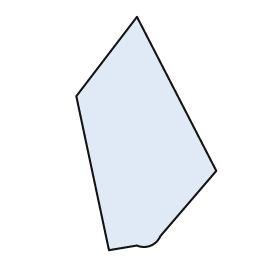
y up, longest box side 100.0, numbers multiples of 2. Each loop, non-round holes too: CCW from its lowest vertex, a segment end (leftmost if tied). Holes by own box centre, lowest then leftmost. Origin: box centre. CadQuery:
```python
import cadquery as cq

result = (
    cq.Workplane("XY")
    .moveTo(-16.0, -50.0)
    .lineTo(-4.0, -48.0)
    .threePointArc((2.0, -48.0), (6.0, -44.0))
    .lineTo(30.0, -16.0)
    .lineTo(-4.0, 50.0)
    .lineTo(-30.0, 16.0)
    .close()
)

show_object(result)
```